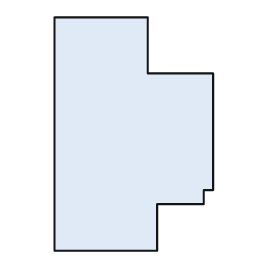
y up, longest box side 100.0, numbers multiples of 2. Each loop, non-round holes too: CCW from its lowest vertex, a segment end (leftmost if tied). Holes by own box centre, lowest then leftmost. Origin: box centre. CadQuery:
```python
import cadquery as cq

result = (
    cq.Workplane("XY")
    .moveTo(-34.0, -50.0)
    .lineTo(10.0, -50.0)
    .lineTo(10.0, -30.0)
    .lineTo(30.0, -30.0)
    .lineTo(30.0, -24.0)
    .lineTo(34.0, -24.0)
    .lineTo(34.0, 26.0)
    .lineTo(6.0, 26.0)
    .lineTo(6.0, 50.0)
    .lineTo(-34.0, 50.0)
    .close()
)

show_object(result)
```